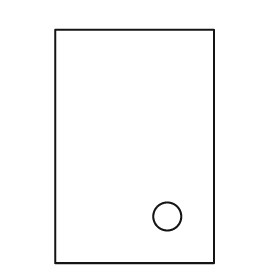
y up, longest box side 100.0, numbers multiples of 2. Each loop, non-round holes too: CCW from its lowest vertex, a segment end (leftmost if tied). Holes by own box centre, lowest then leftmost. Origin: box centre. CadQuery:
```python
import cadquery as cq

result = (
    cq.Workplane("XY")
    .moveTo(-34.0, -50.0)
    .lineTo(34.0, -50.0)
    .lineTo(34.0, 50.0)
    .lineTo(-34.0, 50.0)
    .close()
    .moveTo(14.0, -30.0)
    .circle(6.0)
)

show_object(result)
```